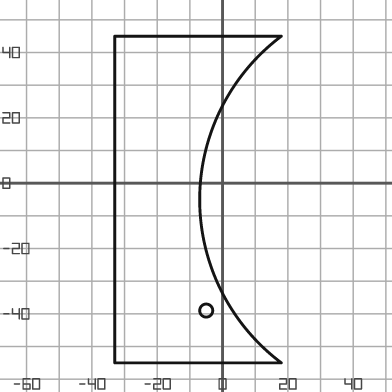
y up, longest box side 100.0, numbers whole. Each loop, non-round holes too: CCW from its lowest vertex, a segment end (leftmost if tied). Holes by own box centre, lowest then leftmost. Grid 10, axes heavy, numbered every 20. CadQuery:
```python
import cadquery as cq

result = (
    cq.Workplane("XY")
    .moveTo(-33.0, -55.0)
    .lineTo(18.0, -55.0)
    .threePointArc((-7.0, -5.0), (18.0, 45.0))
    .lineTo(-33.0, 45.0)
    .close()
    .moveTo(-5.0, -39.0)
    .circle(2.0)
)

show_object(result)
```